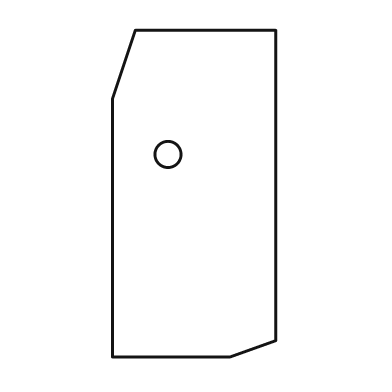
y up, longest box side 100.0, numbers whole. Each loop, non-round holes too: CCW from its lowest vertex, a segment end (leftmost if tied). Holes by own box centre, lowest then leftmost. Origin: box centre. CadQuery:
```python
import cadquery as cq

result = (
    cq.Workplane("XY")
    .moveTo(-25.0, -50.0)
    .lineTo(11.0, -50.0)
    .lineTo(25.0, -45.0)
    .lineTo(25.0, 50.0)
    .lineTo(-18.0, 50.0)
    .lineTo(-25.0, 29.0)
    .close()
    .moveTo(-8.0, 12.0)
    .circle(4.0)
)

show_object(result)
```